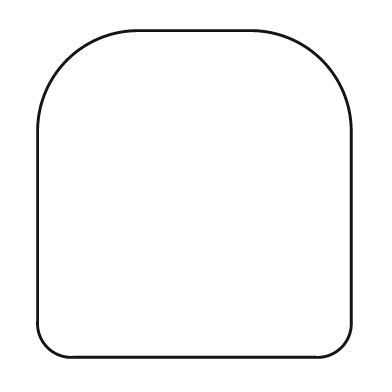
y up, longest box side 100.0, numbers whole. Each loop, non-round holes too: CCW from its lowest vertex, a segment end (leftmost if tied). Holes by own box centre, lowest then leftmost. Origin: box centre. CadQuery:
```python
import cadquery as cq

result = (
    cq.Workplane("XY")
    .moveTo(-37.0, -50.0)
    .lineTo(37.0, -50.0)
    .threePointArc((45.0, -47.0), (48.0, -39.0))
    .lineTo(48.0, 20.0)
    .threePointArc((39.0, 41.0), (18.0, 50.0))
    .lineTo(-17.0, 50.0)
    .threePointArc((-39.0, 41.0), (-48.0, 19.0))
    .lineTo(-48.0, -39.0)
    .threePointArc((-45.0, -47.0), (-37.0, -50.0))
    .close()
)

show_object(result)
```